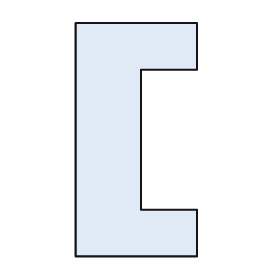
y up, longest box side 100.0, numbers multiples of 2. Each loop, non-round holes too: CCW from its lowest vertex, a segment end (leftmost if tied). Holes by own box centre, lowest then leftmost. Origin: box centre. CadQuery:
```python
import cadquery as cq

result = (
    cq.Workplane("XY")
    .moveTo(-26.0, -50.0)
    .lineTo(26.0, -50.0)
    .lineTo(26.0, -30.0)
    .lineTo(2.0, -30.0)
    .lineTo(2.0, 30.0)
    .lineTo(26.0, 30.0)
    .lineTo(26.0, 50.0)
    .lineTo(-26.0, 50.0)
    .close()
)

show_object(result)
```